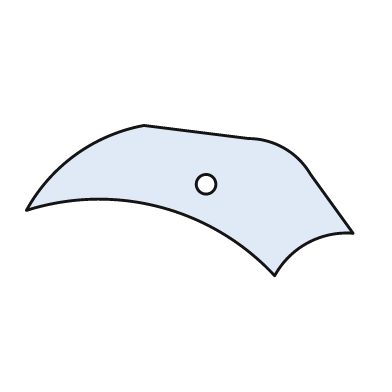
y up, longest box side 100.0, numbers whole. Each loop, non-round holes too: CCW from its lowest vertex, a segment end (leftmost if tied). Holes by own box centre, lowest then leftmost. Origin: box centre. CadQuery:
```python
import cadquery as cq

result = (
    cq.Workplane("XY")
    .moveTo(26.0, -23.0)
    .threePointArc((36.0, -13.0), (50.0, -10.0))
    .lineTo(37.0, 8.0)
    .threePointArc((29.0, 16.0), (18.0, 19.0))
    .lineTo(-14.0, 23.0)
    .threePointArc((-35.0, 14.0), (-50.0, -3.0))
    .threePointArc((-9.0, -2.0), (26.0, -23.0))
    .close()
    .moveTo(5.0, 5.0)
    .circle(3.0)
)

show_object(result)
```